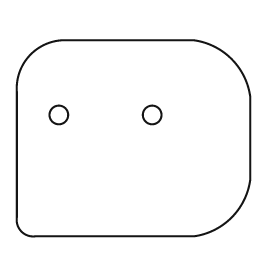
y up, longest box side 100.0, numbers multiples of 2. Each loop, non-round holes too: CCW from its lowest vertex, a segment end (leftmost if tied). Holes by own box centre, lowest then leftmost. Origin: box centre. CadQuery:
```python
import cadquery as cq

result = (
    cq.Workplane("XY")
    .moveTo(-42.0, -42.0)
    .lineTo(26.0, -42.0)
    .threePointArc((42.0, -34.0), (50.0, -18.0))
    .lineTo(50.0, 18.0)
    .threePointArc((42.0, 34.0), (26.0, 42.0))
    .lineTo(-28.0, 42.0)
    .threePointArc((-44.0, 36.0), (-50.0, 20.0))
    .lineTo(-50.0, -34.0)
    .threePointArc((-48.0, -40.0), (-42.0, -42.0))
    .close()
    .moveTo(-32.0, 10.0)
    .circle(4.0)
    .moveTo(8.0, 10.0)
    .circle(4.0)
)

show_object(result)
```